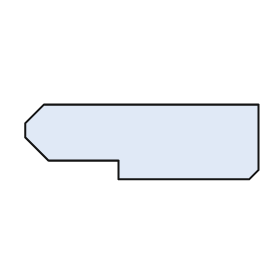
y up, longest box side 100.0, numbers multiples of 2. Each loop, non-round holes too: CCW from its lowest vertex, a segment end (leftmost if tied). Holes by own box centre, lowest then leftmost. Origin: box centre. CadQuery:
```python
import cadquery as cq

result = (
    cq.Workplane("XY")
    .moveTo(-10.0, -16.0)
    .lineTo(46.0, -16.0)
    .lineTo(50.0, -12.0)
    .lineTo(50.0, 16.0)
    .lineTo(-42.0, 16.0)
    .lineTo(-50.0, 8.0)
    .lineTo(-50.0, 2.0)
    .lineTo(-40.0, -8.0)
    .lineTo(-10.0, -8.0)
    .close()
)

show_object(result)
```